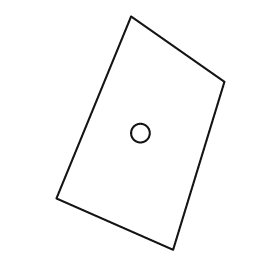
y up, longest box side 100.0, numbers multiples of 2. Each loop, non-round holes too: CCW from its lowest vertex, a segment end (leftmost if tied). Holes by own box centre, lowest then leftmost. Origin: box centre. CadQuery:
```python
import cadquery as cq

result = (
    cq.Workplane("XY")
    .moveTo(14.0, -50.0)
    .lineTo(36.0, 22.0)
    .lineTo(-4.0, 50.0)
    .lineTo(-36.0, -28.0)
    .close()
    .moveTo(0.0, 0.0)
    .circle(4.0)
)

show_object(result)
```